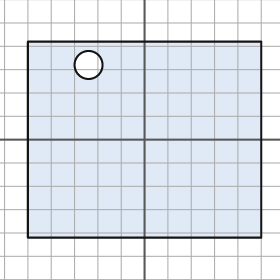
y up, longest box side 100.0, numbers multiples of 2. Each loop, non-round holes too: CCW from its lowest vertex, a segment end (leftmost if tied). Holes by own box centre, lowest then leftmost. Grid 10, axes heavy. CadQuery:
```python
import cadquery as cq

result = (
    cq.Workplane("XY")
    .moveTo(-50.0, -42.0)
    .lineTo(50.0, -42.0)
    .lineTo(50.0, 42.0)
    .lineTo(-50.0, 42.0)
    .close()
    .moveTo(-24.0, 32.0)
    .circle(6.0)
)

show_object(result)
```